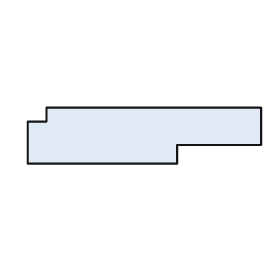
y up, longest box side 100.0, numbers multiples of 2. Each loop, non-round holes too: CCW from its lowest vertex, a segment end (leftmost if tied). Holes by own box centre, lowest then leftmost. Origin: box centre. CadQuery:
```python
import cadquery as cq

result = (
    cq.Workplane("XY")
    .moveTo(-50.0, -12.0)
    .lineTo(14.0, -12.0)
    .lineTo(14.0, -4.0)
    .lineTo(50.0, -4.0)
    .lineTo(50.0, 12.0)
    .lineTo(-42.0, 12.0)
    .lineTo(-42.0, 6.0)
    .lineTo(-50.0, 6.0)
    .close()
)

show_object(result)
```